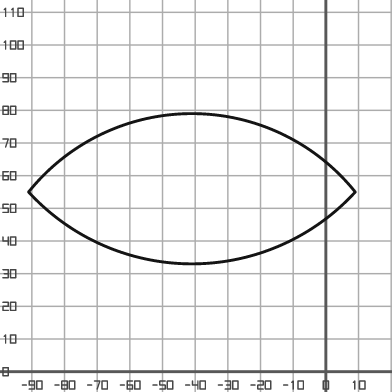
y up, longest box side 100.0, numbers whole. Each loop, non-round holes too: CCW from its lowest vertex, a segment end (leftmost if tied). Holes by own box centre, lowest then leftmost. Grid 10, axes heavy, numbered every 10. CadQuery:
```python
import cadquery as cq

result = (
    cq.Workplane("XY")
    .moveTo(-91.0, 55.0)
    .threePointArc((-41.0, 33.0), (9.0, 55.0))
    .threePointArc((-41.0, 79.0), (-91.0, 55.0))
    .close()
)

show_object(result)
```